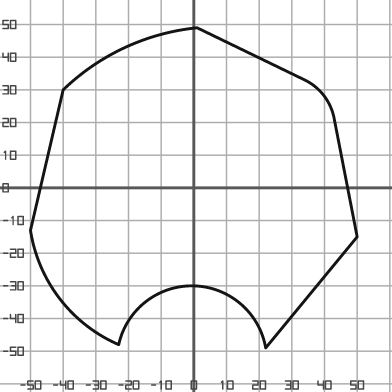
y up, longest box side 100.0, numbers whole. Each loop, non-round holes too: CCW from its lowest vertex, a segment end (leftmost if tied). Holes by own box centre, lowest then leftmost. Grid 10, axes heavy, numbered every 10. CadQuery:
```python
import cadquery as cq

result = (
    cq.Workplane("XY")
    .moveTo(22.0, -49.0)
    .lineTo(50.0, -15.0)
    .lineTo(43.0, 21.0)
    .threePointArc((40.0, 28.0), (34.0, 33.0))
    .lineTo(1.0, 49.0)
    .threePointArc((-21.0, 43.0), (-40.0, 30.0))
    .lineTo(-50.0, -13.0)
    .threePointArc((-41.0, -34.0), (-23.0, -48.0))
    .threePointArc((0.0, -30.0), (22.0, -49.0))
    .close()
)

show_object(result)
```